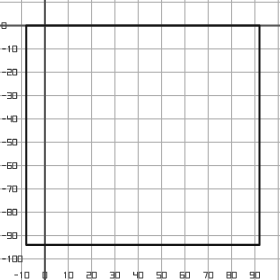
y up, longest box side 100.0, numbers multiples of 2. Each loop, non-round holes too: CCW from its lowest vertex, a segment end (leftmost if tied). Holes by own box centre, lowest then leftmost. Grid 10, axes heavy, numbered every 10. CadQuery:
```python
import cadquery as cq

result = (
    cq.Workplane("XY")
    .moveTo(-8.0, -94.0)
    .lineTo(92.0, -94.0)
    .lineTo(92.0, 0.0)
    .lineTo(-8.0, 0.0)
    .close()
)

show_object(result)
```